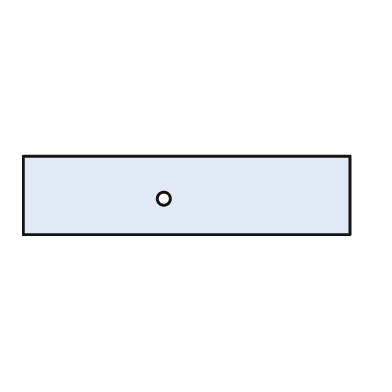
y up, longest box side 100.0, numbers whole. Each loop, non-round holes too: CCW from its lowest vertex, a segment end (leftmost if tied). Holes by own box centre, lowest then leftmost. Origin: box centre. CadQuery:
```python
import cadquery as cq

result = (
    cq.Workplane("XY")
    .moveTo(-50.0, -12.0)
    .lineTo(50.0, -12.0)
    .lineTo(50.0, 12.0)
    .lineTo(-50.0, 12.0)
    .close()
    .moveTo(-7.0, -1.0)
    .circle(2.0)
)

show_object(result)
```